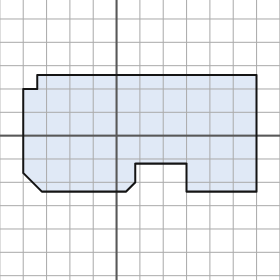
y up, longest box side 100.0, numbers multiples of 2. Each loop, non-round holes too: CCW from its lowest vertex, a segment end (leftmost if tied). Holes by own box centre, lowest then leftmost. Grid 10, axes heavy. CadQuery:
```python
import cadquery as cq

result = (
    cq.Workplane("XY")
    .moveTo(-32.0, -24.0)
    .lineTo(4.0, -24.0)
    .lineTo(8.0, -20.0)
    .lineTo(8.0, -12.0)
    .lineTo(30.0, -12.0)
    .lineTo(30.0, -24.0)
    .lineTo(60.0, -24.0)
    .lineTo(60.0, 26.0)
    .lineTo(-34.0, 26.0)
    .lineTo(-34.0, 20.0)
    .lineTo(-40.0, 20.0)
    .lineTo(-40.0, -16.0)
    .close()
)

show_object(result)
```